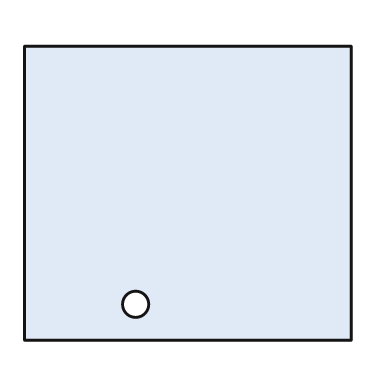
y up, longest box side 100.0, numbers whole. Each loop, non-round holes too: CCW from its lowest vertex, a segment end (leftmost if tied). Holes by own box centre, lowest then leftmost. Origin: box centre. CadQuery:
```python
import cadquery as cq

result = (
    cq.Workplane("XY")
    .moveTo(-50.0, -45.0)
    .lineTo(50.0, -45.0)
    .lineTo(50.0, 45.0)
    .lineTo(-50.0, 45.0)
    .close()
    .moveTo(-16.0, -34.0)
    .circle(4.0)
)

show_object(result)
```